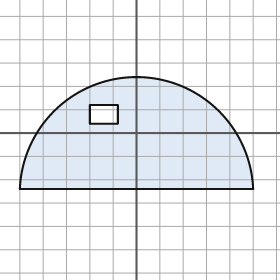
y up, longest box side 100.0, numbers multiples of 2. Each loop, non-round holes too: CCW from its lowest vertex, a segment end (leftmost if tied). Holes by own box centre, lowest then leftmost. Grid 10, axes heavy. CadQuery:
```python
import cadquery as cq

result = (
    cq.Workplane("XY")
    .moveTo(-50.0, -24.0)
    .lineTo(50.0, -24.0)
    .threePointArc((0.0, 24.0), (-50.0, -24.0))
    .close()
    .moveTo(-20.0, 4.0)
    .lineTo(-8.0, 4.0)
    .lineTo(-8.0, 12.0)
    .lineTo(-20.0, 12.0)
    .close()
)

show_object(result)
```